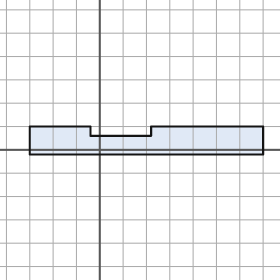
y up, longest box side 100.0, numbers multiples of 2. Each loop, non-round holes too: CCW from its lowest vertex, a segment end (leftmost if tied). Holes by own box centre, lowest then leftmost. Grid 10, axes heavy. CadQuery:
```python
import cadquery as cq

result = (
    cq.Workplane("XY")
    .moveTo(-30.0, -2.0)
    .lineTo(70.0, -2.0)
    .lineTo(70.0, 10.0)
    .lineTo(22.0, 10.0)
    .lineTo(22.0, 6.0)
    .lineTo(-4.0, 6.0)
    .lineTo(-4.0, 10.0)
    .lineTo(-30.0, 10.0)
    .close()
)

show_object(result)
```